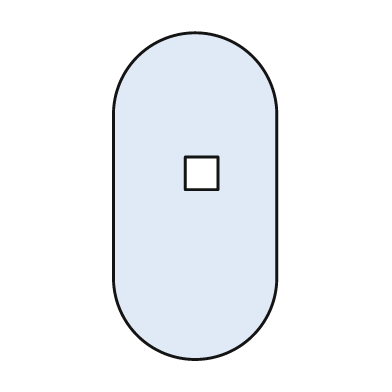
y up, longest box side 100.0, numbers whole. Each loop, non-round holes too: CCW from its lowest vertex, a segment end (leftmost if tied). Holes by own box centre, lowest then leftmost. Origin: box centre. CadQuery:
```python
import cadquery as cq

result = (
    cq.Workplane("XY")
    .moveTo(-25.0, -25.0)
    .threePointArc((0.0, -50.0), (25.0, -25.0))
    .lineTo(25.0, 25.0)
    .threePointArc((0.0, 50.0), (-25.0, 25.0))
    .close()
    .moveTo(-3.0, 2.0)
    .lineTo(7.0, 2.0)
    .lineTo(7.0, 12.0)
    .lineTo(-3.0, 12.0)
    .close()
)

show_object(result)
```